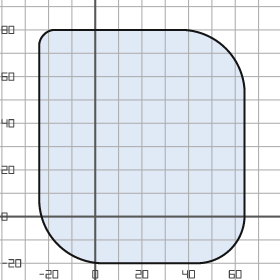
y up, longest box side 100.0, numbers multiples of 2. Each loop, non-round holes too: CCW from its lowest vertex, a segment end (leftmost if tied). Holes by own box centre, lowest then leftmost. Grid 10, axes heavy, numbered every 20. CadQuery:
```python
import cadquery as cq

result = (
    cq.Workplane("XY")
    .moveTo(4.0, -20.0)
    .lineTo(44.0, -20.0)
    .threePointArc((58.0, -14.0), (64.0, 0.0))
    .lineTo(64.0, 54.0)
    .threePointArc((56.0, 72.0), (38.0, 80.0))
    .lineTo(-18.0, 80.0)
    .threePointArc((-22.0, 78.0), (-24.0, 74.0))
    .lineTo(-24.0, 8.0)
    .threePointArc((-16.0, -12.0), (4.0, -20.0))
    .close()
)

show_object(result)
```